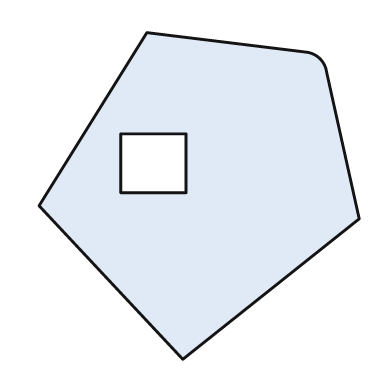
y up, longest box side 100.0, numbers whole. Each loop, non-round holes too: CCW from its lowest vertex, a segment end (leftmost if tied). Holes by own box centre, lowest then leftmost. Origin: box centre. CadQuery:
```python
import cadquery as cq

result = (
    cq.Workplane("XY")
    .moveTo(-5.0, -50.0)
    .lineTo(49.0, -7.0)
    .lineTo(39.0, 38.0)
    .threePointArc((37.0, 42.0), (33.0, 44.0))
    .lineTo(-16.0, 50.0)
    .lineTo(-49.0, -3.0)
    .close()
    .moveTo(-24.0, 1.0)
    .lineTo(-4.0, 1.0)
    .lineTo(-4.0, 19.0)
    .lineTo(-24.0, 19.0)
    .close()
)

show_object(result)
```